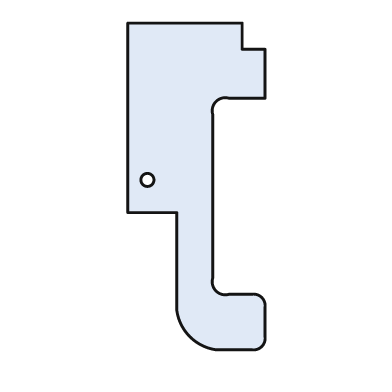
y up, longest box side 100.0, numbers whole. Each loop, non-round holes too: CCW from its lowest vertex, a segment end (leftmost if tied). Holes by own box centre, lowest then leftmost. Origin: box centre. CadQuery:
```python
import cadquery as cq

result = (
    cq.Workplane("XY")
    .moveTo(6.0, -50.0)
    .lineTo(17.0, -50.0)
    .threePointArc((20.0, -49.0), (21.0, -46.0))
    .lineTo(21.0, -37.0)
    .threePointArc((20.0, -34.0), (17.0, -33.0))
    .lineTo(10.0, -33.0)
    .threePointArc((6.0, -32.0), (5.0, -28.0))
    .lineTo(5.0, 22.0)
    .threePointArc((6.0, 26.0), (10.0, 27.0))
    .lineTo(21.0, 27.0)
    .lineTo(21.0, 42.0)
    .lineTo(14.0, 42.0)
    .lineTo(14.0, 50.0)
    .lineTo(-21.0, 50.0)
    .lineTo(-21.0, -8.0)
    .lineTo(-6.0, -8.0)
    .lineTo(-6.0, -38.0)
    .threePointArc((-2.0, -46.0), (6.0, -50.0))
    .close()
    .moveTo(-15.0, 2.0)
    .circle(2.0)
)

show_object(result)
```